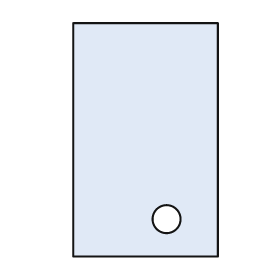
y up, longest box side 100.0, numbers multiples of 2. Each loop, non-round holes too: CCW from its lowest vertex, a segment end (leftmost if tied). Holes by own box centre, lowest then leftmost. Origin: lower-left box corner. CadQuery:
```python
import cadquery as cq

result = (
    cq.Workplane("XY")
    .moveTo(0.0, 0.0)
    .lineTo(62.0, 0.0)
    .lineTo(62.0, 100.0)
    .lineTo(0.0, 100.0)
    .close()
    .moveTo(40.0, 16.0)
    .circle(6.0)
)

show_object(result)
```